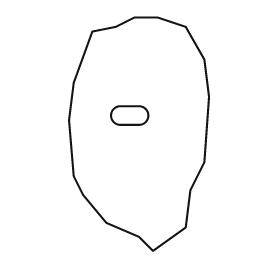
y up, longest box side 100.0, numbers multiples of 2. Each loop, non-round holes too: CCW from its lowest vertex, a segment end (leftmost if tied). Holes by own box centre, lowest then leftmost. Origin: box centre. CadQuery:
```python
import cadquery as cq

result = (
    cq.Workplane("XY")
    .moveTo(6.0, -50.0)
    .lineTo(20.0, -40.0)
    .lineTo(22.0, -24.0)
    .lineTo(28.0, -12.0)
    .lineTo(30.0, 16.0)
    .lineTo(28.0, 32.0)
    .lineTo(20.0, 46.0)
    .lineTo(8.0, 50.0)
    .lineTo(-2.0, 50.0)
    .lineTo(-10.0, 46.0)
    .lineTo(-20.0, 44.0)
    .lineTo(-28.0, 22.0)
    .lineTo(-30.0, 6.0)
    .lineTo(-28.0, -18.0)
    .lineTo(-24.0, -26.0)
    .lineTo(-14.0, -38.0)
    .lineTo(0.0, -44.0)
    .close()
    .moveTo(-8.0, 4.0)
    .lineTo(0.0, 4.0)
    .threePointArc((4.0, 8.0), (0.0, 12.0))
    .lineTo(-8.0, 12.0)
    .threePointArc((-12.0, 8.0), (-8.0, 4.0))
    .close()
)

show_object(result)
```